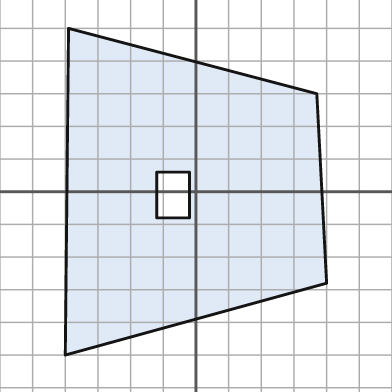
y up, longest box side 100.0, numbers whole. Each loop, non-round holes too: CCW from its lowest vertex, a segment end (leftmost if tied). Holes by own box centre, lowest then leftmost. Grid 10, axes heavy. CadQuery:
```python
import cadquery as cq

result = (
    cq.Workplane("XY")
    .moveTo(-40.0, -50.0)
    .lineTo(40.0, -28.0)
    .lineTo(37.0, 30.0)
    .lineTo(-39.0, 50.0)
    .close()
    .moveTo(-12.0, -8.0)
    .lineTo(-2.0, -8.0)
    .lineTo(-2.0, 6.0)
    .lineTo(-12.0, 6.0)
    .close()
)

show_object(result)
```